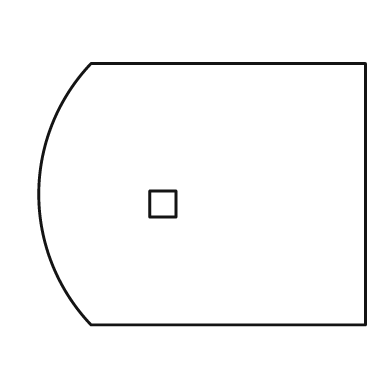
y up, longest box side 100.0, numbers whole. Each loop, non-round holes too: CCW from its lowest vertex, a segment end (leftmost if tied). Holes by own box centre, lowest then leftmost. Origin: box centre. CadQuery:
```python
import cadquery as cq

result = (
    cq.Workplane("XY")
    .moveTo(-34.0, -40.0)
    .lineTo(50.0, -40.0)
    .lineTo(50.0, 40.0)
    .lineTo(-34.0, 40.0)
    .threePointArc((-50.0, 0.0), (-34.0, -40.0))
    .close()
    .moveTo(-16.0, -7.0)
    .lineTo(-8.0, -7.0)
    .lineTo(-8.0, 1.0)
    .lineTo(-16.0, 1.0)
    .close()
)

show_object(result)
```